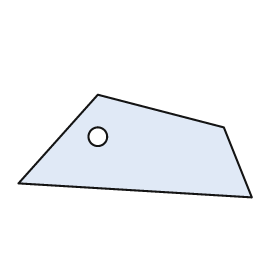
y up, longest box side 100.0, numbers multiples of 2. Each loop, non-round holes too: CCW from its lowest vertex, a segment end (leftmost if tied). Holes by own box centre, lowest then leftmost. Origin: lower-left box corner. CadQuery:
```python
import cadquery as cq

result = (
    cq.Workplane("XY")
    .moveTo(100.0, 0.0)
    .lineTo(88.0, 30.0)
    .lineTo(34.0, 44.0)
    .lineTo(0.0, 6.0)
    .close()
    .moveTo(34.0, 26.0)
    .circle(4.0)
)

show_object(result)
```